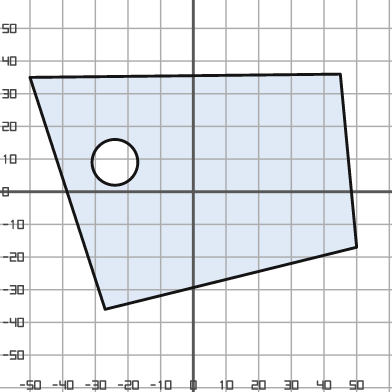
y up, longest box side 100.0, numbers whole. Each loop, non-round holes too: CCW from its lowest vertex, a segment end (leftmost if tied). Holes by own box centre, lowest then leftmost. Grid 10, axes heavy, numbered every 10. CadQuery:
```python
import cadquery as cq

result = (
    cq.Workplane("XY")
    .moveTo(-27.0, -36.0)
    .lineTo(50.0, -17.0)
    .lineTo(45.0, 36.0)
    .lineTo(-50.0, 35.0)
    .close()
    .moveTo(-24.0, 9.0)
    .circle(7.0)
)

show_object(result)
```